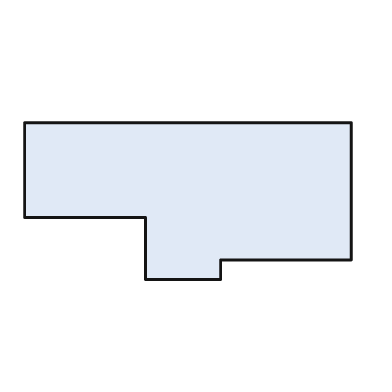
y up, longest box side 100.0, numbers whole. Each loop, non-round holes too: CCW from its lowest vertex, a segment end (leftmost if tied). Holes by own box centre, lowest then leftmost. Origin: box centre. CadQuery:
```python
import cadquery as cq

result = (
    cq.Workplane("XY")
    .moveTo(-13.0, -24.0)
    .lineTo(10.0, -24.0)
    .lineTo(10.0, -18.0)
    .lineTo(50.0, -18.0)
    .lineTo(50.0, 24.0)
    .lineTo(-50.0, 24.0)
    .lineTo(-50.0, -5.0)
    .lineTo(-13.0, -5.0)
    .close()
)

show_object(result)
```